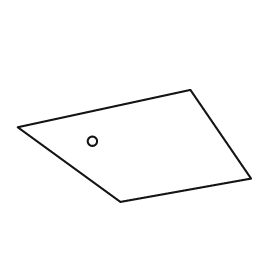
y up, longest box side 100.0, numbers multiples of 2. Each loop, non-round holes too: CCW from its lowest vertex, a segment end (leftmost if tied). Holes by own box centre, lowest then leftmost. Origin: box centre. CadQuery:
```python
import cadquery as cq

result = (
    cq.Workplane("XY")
    .moveTo(-6.0, -24.0)
    .lineTo(50.0, -14.0)
    .lineTo(24.0, 24.0)
    .lineTo(-50.0, 8.0)
    .close()
    .moveTo(-18.0, 2.0)
    .circle(2.0)
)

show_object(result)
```